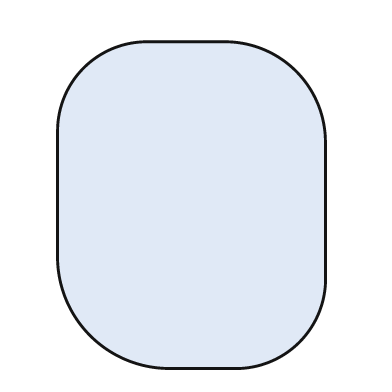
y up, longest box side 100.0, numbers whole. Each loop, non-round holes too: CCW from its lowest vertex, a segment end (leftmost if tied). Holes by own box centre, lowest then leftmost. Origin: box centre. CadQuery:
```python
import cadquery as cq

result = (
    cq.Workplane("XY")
    .moveTo(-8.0, -50.0)
    .lineTo(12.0, -50.0)
    .threePointArc((33.0, -42.0), (41.0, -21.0))
    .lineTo(41.0, 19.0)
    .threePointArc((32.0, 41.0), (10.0, 50.0))
    .lineTo(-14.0, 50.0)
    .threePointArc((-33.0, 42.0), (-41.0, 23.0))
    .lineTo(-41.0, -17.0)
    .threePointArc((-31.0, -40.0), (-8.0, -50.0))
    .close()
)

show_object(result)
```